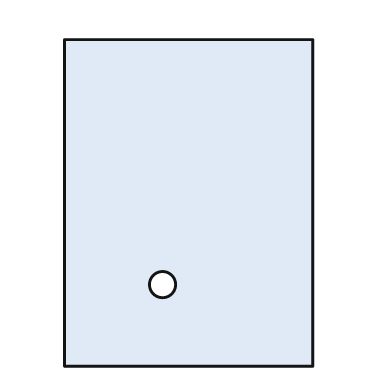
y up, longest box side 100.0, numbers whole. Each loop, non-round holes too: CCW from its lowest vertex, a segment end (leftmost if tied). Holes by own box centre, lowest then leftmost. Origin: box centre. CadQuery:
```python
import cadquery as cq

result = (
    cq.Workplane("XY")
    .moveTo(-38.0, -50.0)
    .lineTo(38.0, -50.0)
    .lineTo(38.0, 50.0)
    .lineTo(-38.0, 50.0)
    .close()
    .moveTo(-8.0, -25.0)
    .circle(4.0)
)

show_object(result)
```